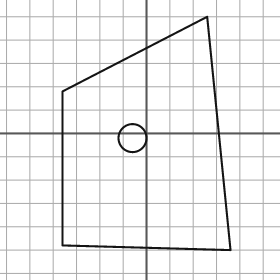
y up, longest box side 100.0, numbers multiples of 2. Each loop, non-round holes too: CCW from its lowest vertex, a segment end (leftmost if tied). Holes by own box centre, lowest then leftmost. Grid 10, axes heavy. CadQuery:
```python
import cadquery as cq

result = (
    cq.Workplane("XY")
    .moveTo(36.0, -50.0)
    .lineTo(26.0, 50.0)
    .lineTo(-36.0, 18.0)
    .lineTo(-36.0, -48.0)
    .close()
    .moveTo(-6.0, -2.0)
    .circle(6.0)
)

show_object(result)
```